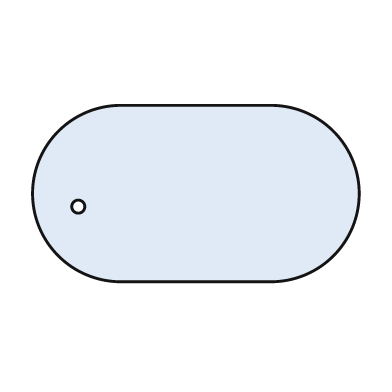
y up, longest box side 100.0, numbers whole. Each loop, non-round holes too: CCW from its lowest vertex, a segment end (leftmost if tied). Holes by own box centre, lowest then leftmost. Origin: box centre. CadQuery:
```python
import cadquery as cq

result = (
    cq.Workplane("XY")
    .moveTo(-23.0, -27.0)
    .lineTo(23.0, -27.0)
    .threePointArc((50.0, 0.0), (23.0, 27.0))
    .lineTo(-23.0, 27.0)
    .threePointArc((-50.0, 0.0), (-23.0, -27.0))
    .close()
    .moveTo(-36.0, -4.0)
    .circle(2.0)
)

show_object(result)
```